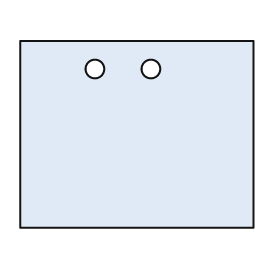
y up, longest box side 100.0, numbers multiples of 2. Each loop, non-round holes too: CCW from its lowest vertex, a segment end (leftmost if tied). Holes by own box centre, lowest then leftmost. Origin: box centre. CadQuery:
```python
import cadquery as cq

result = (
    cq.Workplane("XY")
    .moveTo(-50.0, -40.0)
    .lineTo(50.0, -40.0)
    .lineTo(50.0, 40.0)
    .lineTo(-50.0, 40.0)
    .close()
    .moveTo(-18.0, 28.0)
    .circle(4.0)
    .moveTo(6.0, 28.0)
    .circle(4.0)
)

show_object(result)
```